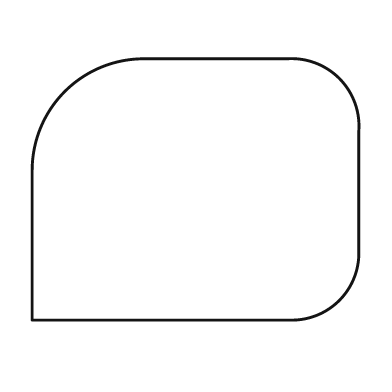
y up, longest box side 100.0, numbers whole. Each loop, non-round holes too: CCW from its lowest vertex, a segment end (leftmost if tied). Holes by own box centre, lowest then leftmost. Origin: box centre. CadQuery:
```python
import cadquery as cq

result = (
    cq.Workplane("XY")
    .moveTo(-50.0, -40.0)
    .lineTo(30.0, -40.0)
    .threePointArc((44.0, -34.0), (50.0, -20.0))
    .lineTo(50.0, 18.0)
    .threePointArc((44.0, 34.0), (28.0, 40.0))
    .lineTo(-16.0, 40.0)
    .threePointArc((-40.0, 30.0), (-50.0, 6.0))
    .close()
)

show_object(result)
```